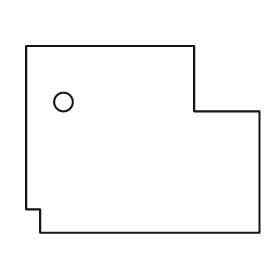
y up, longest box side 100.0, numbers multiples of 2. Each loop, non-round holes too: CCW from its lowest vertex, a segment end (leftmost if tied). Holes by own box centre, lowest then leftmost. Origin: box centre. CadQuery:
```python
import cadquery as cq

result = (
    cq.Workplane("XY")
    .moveTo(-44.0, -40.0)
    .lineTo(50.0, -40.0)
    .lineTo(50.0, 12.0)
    .lineTo(22.0, 12.0)
    .lineTo(22.0, 40.0)
    .lineTo(-50.0, 40.0)
    .lineTo(-50.0, -30.0)
    .lineTo(-44.0, -30.0)
    .close()
    .moveTo(-34.0, 16.0)
    .circle(4.0)
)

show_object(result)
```